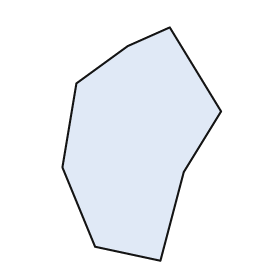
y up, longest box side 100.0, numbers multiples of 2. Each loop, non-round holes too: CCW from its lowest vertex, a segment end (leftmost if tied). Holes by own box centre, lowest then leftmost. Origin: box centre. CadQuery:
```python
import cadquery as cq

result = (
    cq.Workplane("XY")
    .moveTo(8.0, -50.0)
    .lineTo(18.0, -12.0)
    .lineTo(34.0, 14.0)
    .lineTo(12.0, 50.0)
    .lineTo(-6.0, 42.0)
    .lineTo(-28.0, 26.0)
    .lineTo(-34.0, -10.0)
    .lineTo(-20.0, -44.0)
    .close()
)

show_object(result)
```